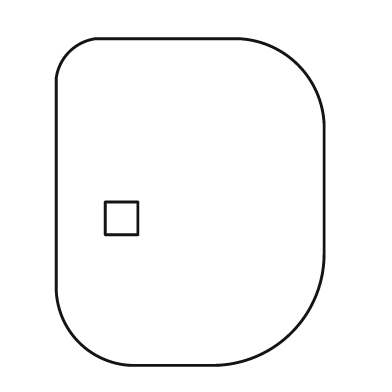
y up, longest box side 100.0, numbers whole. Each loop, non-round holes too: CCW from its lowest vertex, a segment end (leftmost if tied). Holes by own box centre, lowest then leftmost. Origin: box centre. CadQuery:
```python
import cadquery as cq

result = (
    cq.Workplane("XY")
    .moveTo(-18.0, -50.0)
    .lineTo(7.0, -50.0)
    .threePointArc((31.0, -40.0), (41.0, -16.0))
    .lineTo(41.0, 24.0)
    .threePointArc((33.0, 42.0), (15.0, 50.0))
    .lineTo(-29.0, 50.0)
    .threePointArc((-37.0, 46.0), (-41.0, 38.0))
    .lineTo(-41.0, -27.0)
    .threePointArc((-34.0, -43.0), (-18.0, -50.0))
    .close()
    .moveTo(-26.0, -10.0)
    .lineTo(-16.0, -10.0)
    .lineTo(-16.0, 0.0)
    .lineTo(-26.0, 0.0)
    .close()
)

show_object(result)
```